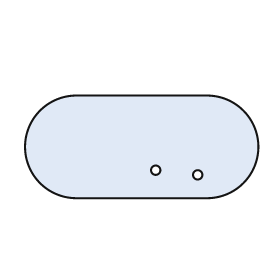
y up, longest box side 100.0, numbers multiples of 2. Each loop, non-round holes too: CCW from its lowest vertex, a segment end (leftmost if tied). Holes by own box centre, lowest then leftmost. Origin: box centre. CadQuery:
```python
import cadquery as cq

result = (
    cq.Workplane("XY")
    .moveTo(-28.0, -22.0)
    .lineTo(28.0, -22.0)
    .threePointArc((50.0, 0.0), (28.0, 22.0))
    .lineTo(-28.0, 22.0)
    .threePointArc((-50.0, 0.0), (-28.0, -22.0))
    .close()
    .moveTo(24.0, -12.0)
    .circle(2.0)
    .moveTo(6.0, -10.0)
    .circle(2.0)
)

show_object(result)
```